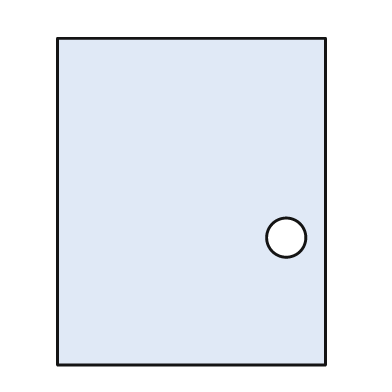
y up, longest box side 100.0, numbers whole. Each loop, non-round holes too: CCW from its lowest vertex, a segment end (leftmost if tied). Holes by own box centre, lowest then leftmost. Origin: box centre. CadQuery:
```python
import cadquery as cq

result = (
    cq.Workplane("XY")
    .moveTo(-41.0, -50.0)
    .lineTo(41.0, -50.0)
    .lineTo(41.0, 50.0)
    .lineTo(-41.0, 50.0)
    .close()
    .moveTo(29.0, -11.0)
    .circle(6.0)
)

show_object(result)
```